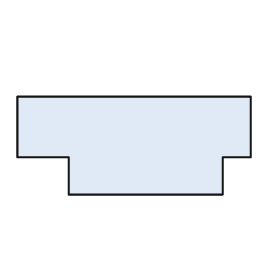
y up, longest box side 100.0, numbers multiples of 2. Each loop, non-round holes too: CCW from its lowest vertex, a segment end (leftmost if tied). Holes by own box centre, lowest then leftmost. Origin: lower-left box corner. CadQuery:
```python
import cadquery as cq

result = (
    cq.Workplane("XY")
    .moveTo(22.0, 0.0)
    .lineTo(88.0, 0.0)
    .lineTo(88.0, 16.0)
    .lineTo(100.0, 16.0)
    .lineTo(100.0, 42.0)
    .lineTo(0.0, 42.0)
    .lineTo(0.0, 16.0)
    .lineTo(22.0, 16.0)
    .close()
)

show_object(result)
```